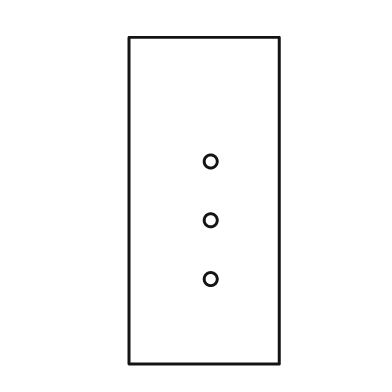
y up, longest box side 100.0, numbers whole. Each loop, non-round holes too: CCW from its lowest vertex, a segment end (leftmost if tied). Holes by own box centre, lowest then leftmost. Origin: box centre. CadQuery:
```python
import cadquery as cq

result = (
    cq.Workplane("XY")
    .moveTo(-23.0, -50.0)
    .lineTo(23.0, -50.0)
    .lineTo(23.0, 50.0)
    .lineTo(-23.0, 50.0)
    .close()
    .moveTo(2.0, -24.0)
    .circle(2.0)
    .moveTo(2.0, -6.0)
    .circle(2.0)
    .moveTo(2.0, 12.0)
    .circle(2.0)
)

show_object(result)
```